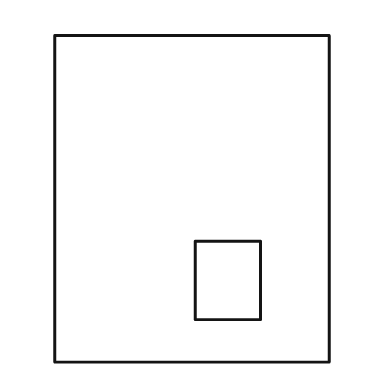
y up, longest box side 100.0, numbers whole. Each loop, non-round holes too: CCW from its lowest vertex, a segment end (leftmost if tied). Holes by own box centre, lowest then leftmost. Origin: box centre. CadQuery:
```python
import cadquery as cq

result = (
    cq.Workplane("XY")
    .moveTo(-42.0, -50.0)
    .lineTo(42.0, -50.0)
    .lineTo(42.0, 50.0)
    .lineTo(-42.0, 50.0)
    .close()
    .moveTo(1.0, -37.0)
    .lineTo(21.0, -37.0)
    .lineTo(21.0, -13.0)
    .lineTo(1.0, -13.0)
    .close()
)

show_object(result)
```